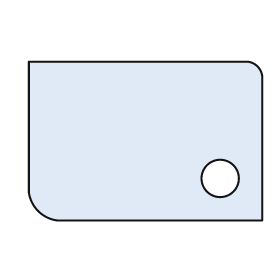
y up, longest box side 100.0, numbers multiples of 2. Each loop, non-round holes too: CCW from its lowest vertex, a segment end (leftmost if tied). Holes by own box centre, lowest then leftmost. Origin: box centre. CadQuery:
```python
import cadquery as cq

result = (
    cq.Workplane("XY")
    .moveTo(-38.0, -34.0)
    .lineTo(50.0, -34.0)
    .lineTo(50.0, 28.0)
    .threePointArc((48.0, 32.0), (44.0, 34.0))
    .lineTo(-50.0, 34.0)
    .lineTo(-50.0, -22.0)
    .threePointArc((-46.0, -30.0), (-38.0, -34.0))
    .close()
    .moveTo(32.0, -16.0)
    .circle(8.0)
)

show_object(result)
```